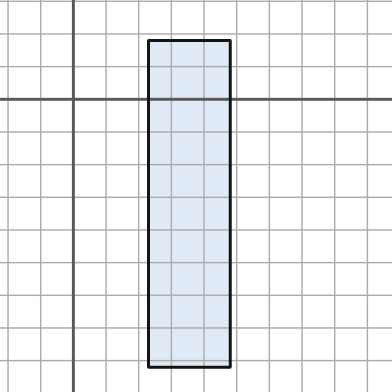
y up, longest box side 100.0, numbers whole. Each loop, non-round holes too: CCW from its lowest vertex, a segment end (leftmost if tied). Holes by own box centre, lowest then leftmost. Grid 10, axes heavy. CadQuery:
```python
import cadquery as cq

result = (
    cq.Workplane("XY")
    .moveTo(23.0, -82.0)
    .lineTo(48.0, -82.0)
    .lineTo(48.0, 18.0)
    .lineTo(23.0, 18.0)
    .close()
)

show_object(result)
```